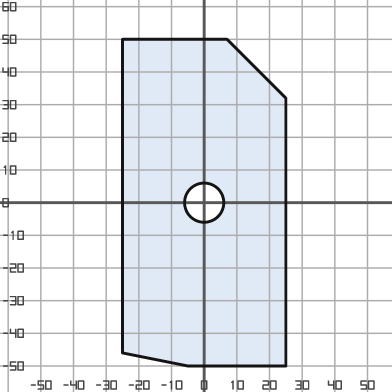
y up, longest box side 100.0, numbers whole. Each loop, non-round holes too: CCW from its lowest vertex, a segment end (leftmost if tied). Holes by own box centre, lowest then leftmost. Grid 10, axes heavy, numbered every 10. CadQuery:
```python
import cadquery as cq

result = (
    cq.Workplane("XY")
    .moveTo(-5.0, -50.0)
    .lineTo(25.0, -50.0)
    .lineTo(25.0, 32.0)
    .lineTo(7.0, 50.0)
    .lineTo(-25.0, 50.0)
    .lineTo(-25.0, -46.0)
    .close()
    .moveTo(0.0, 0.0)
    .circle(6.0)
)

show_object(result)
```